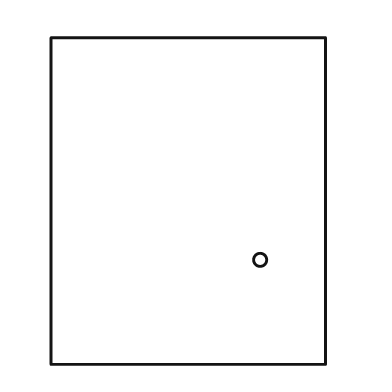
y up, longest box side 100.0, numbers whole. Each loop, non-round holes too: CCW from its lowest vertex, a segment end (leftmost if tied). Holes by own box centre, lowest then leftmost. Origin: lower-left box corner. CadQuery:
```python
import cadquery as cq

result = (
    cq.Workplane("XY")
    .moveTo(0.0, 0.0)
    .lineTo(84.0, 0.0)
    .lineTo(84.0, 100.0)
    .lineTo(0.0, 100.0)
    .close()
    .moveTo(64.0, 32.0)
    .circle(2.0)
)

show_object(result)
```